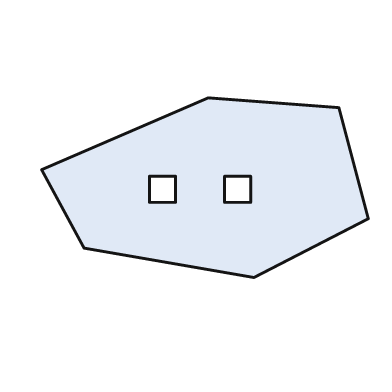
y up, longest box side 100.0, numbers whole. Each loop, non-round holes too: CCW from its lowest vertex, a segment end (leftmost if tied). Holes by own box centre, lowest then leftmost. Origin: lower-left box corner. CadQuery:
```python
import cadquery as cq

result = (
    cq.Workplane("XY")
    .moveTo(65.0, 0.0)
    .lineTo(100.0, 18.0)
    .lineTo(91.0, 52.0)
    .lineTo(51.0, 55.0)
    .lineTo(0.0, 33.0)
    .lineTo(13.0, 9.0)
    .close()
    .moveTo(33.0, 23.0)
    .lineTo(41.0, 23.0)
    .lineTo(41.0, 31.0)
    .lineTo(33.0, 31.0)
    .close()
    .moveTo(56.0, 23.0)
    .lineTo(64.0, 23.0)
    .lineTo(64.0, 31.0)
    .lineTo(56.0, 31.0)
    .close()
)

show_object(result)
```